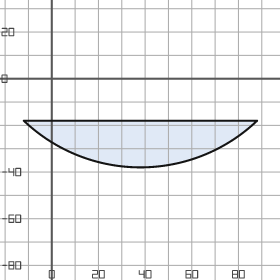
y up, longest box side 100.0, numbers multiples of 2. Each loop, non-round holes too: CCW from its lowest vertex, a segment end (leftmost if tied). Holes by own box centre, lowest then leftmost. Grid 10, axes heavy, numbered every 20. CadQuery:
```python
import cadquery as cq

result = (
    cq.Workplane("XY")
    .moveTo(-12.0, -18.0)
    .threePointArc((38.0, -38.0), (88.0, -18.0))
    .close()
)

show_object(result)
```